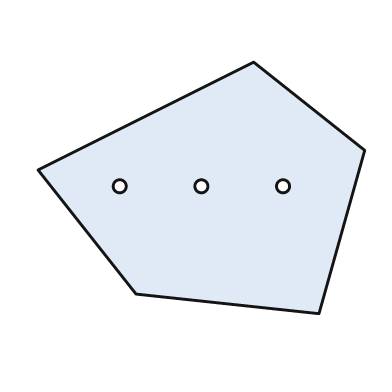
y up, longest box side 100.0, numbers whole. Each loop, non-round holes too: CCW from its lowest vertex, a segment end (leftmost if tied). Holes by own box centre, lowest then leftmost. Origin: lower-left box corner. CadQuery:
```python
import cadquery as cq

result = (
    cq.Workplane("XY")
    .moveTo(86.0, 0.0)
    .lineTo(100.0, 50.0)
    .lineTo(66.0, 77.0)
    .lineTo(0.0, 44.0)
    .lineTo(30.0, 6.0)
    .close()
    .moveTo(25.0, 39.0)
    .circle(2.0)
    .moveTo(50.0, 39.0)
    .circle(2.0)
    .moveTo(75.0, 39.0)
    .circle(2.0)
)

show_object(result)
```